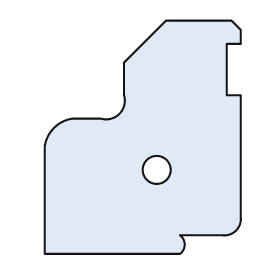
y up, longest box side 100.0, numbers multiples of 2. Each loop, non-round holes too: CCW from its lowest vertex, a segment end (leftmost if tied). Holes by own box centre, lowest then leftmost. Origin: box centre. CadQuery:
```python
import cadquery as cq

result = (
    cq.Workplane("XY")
    .moveTo(-42.0, -50.0)
    .lineTo(16.0, -50.0)
    .threePointArc((18.0, -46.0), (16.0, -42.0))
    .lineTo(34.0, -42.0)
    .threePointArc((40.0, -40.0), (42.0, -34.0))
    .lineTo(42.0, 18.0)
    .lineTo(36.0, 18.0)
    .lineTo(36.0, 40.0)
    .lineTo(42.0, 40.0)
    .lineTo(42.0, 46.0)
    .lineTo(38.0, 50.0)
    .lineTo(10.0, 50.0)
    .lineTo(-8.0, 32.0)
    .lineTo(-8.0, 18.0)
    .threePointArc((-10.0, 10.0), (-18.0, 8.0))
    .lineTo(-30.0, 8.0)
    .threePointArc((-38.0, 4.0), (-42.0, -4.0))
    .close()
    .moveTo(6.0, -14.0)
    .circle(6.0)
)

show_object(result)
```